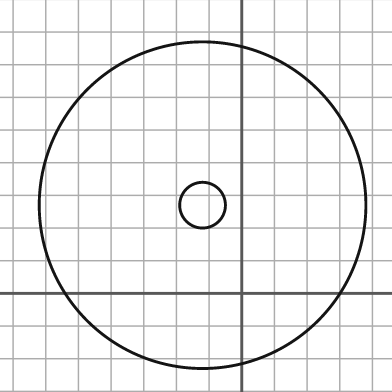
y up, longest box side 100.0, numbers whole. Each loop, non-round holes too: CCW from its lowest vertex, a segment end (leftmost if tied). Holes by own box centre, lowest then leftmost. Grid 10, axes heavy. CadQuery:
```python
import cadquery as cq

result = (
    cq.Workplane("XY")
    .moveTo(-12.0, 27.0)
    .circle(50.0)
    .moveTo(-12.0, 27.0)
    .circle(7.0)
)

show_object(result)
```